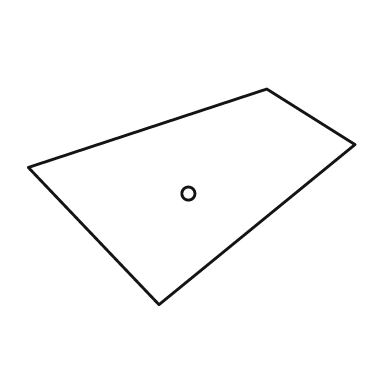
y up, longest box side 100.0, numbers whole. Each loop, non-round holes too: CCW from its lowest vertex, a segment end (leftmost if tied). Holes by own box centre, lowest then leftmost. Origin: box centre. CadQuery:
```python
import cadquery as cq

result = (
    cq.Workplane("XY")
    .moveTo(-10.0, -33.0)
    .lineTo(50.0, 16.0)
    .lineTo(23.0, 33.0)
    .lineTo(-50.0, 9.0)
    .close()
    .moveTo(-1.0, 1.0)
    .circle(2.0)
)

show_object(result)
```